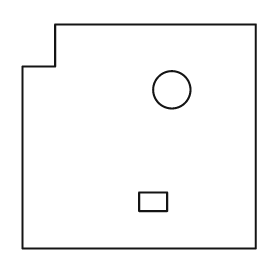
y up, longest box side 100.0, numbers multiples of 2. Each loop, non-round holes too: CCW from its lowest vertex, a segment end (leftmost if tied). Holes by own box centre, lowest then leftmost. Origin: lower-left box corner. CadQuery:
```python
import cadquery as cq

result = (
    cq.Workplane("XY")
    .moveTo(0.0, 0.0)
    .lineTo(100.0, 0.0)
    .lineTo(100.0, 96.0)
    .lineTo(14.0, 96.0)
    .lineTo(14.0, 78.0)
    .lineTo(0.0, 78.0)
    .close()
    .moveTo(50.0, 16.0)
    .lineTo(62.0, 16.0)
    .lineTo(62.0, 24.0)
    .lineTo(50.0, 24.0)
    .close()
    .moveTo(64.0, 68.0)
    .circle(8.0)
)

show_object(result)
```